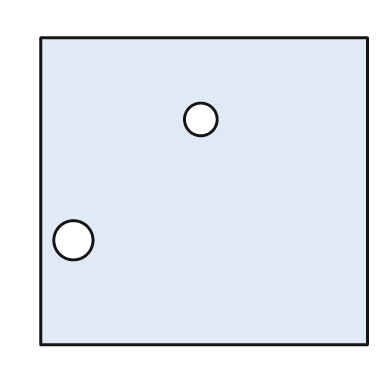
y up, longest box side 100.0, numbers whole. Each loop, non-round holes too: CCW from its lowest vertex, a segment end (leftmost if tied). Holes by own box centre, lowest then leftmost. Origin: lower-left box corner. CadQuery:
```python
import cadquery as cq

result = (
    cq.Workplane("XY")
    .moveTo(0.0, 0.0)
    .lineTo(100.0, 0.0)
    .lineTo(100.0, 94.0)
    .lineTo(0.0, 94.0)
    .close()
    .moveTo(10.0, 32.0)
    .circle(6.0)
    .moveTo(49.0, 69.0)
    .circle(5.0)
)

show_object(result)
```